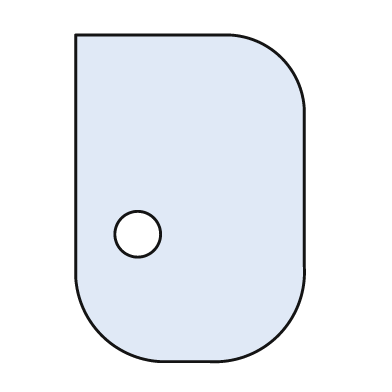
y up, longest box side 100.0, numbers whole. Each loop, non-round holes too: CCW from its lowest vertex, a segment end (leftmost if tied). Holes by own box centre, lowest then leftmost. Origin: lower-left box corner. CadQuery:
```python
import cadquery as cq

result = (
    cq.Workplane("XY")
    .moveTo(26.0, 0.0)
    .lineTo(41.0, 0.0)
    .threePointArc((62.0, 8.0), (70.0, 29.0))
    .lineTo(70.0, 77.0)
    .threePointArc((63.0, 93.0), (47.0, 100.0))
    .lineTo(0.0, 100.0)
    .lineTo(0.0, 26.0)
    .threePointArc((8.0, 8.0), (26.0, 0.0))
    .close()
    .moveTo(19.0, 39.0)
    .circle(7.0)
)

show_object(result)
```